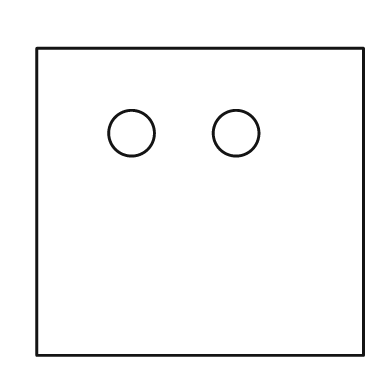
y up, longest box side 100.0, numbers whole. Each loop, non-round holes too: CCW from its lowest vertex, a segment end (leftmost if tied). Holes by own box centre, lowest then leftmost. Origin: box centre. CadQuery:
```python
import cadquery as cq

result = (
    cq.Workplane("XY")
    .moveTo(-50.0, -47.0)
    .lineTo(50.0, -47.0)
    .lineTo(50.0, 47.0)
    .lineTo(-50.0, 47.0)
    .close()
    .moveTo(-21.0, 21.0)
    .circle(7.0)
    .moveTo(11.0, 21.0)
    .circle(7.0)
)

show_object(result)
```